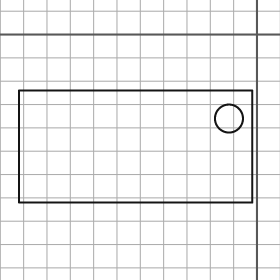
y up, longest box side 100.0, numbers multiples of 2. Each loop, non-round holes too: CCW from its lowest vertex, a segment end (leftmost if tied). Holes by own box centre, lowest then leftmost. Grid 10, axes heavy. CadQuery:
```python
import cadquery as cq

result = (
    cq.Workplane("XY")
    .moveTo(-102.0, -72.0)
    .lineTo(-2.0, -72.0)
    .lineTo(-2.0, -24.0)
    .lineTo(-102.0, -24.0)
    .close()
    .moveTo(-12.0, -36.0)
    .circle(6.0)
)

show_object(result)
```